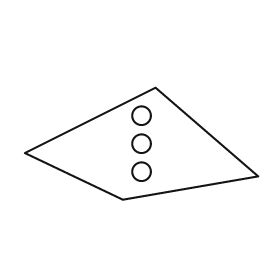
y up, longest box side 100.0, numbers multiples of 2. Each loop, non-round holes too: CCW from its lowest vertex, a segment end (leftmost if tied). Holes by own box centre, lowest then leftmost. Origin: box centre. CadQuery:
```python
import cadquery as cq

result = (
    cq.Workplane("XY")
    .moveTo(-8.0, -24.0)
    .lineTo(50.0, -14.0)
    .lineTo(6.0, 24.0)
    .lineTo(-50.0, -4.0)
    .close()
    .moveTo(0.0, -12.0)
    .circle(4.0)
    .moveTo(0.0, 0.0)
    .circle(4.0)
    .moveTo(0.0, 12.0)
    .circle(4.0)
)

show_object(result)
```